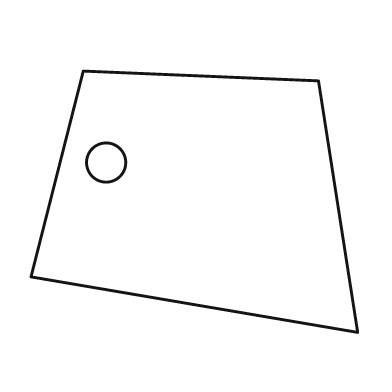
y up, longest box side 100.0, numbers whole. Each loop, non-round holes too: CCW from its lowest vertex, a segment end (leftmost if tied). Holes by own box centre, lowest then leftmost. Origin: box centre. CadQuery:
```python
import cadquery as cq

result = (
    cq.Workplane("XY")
    .moveTo(50.0, -40.0)
    .lineTo(38.0, 37.0)
    .lineTo(-34.0, 40.0)
    .lineTo(-50.0, -23.0)
    .close()
    .moveTo(-27.0, 12.0)
    .circle(6.0)
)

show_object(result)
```